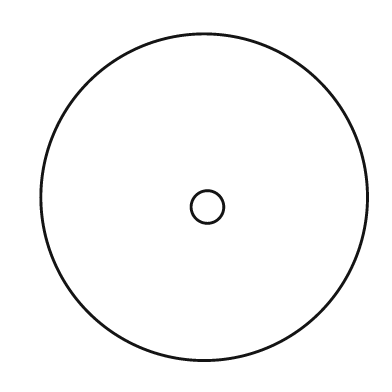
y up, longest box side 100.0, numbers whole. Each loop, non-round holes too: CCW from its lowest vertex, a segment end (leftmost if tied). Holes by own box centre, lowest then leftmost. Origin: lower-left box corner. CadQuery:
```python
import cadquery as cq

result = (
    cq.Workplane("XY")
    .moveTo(50.0, 50.0)
    .circle(50.0)
    .moveTo(51.0, 47.0)
    .circle(5.0)
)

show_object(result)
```